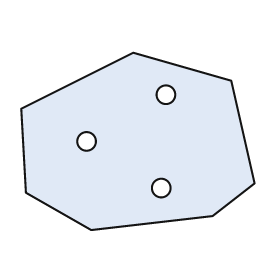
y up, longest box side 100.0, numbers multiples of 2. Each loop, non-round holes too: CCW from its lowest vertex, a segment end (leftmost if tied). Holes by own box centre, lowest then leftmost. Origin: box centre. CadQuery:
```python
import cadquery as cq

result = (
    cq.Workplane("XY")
    .moveTo(-20.0, -38.0)
    .lineTo(32.0, -32.0)
    .lineTo(50.0, -18.0)
    .lineTo(40.0, 26.0)
    .lineTo(-2.0, 38.0)
    .lineTo(-50.0, 14.0)
    .lineTo(-48.0, -22.0)
    .close()
    .moveTo(10.0, -20.0)
    .circle(4.0)
    .moveTo(-22.0, 0.0)
    .circle(4.0)
    .moveTo(12.0, 20.0)
    .circle(4.0)
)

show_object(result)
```